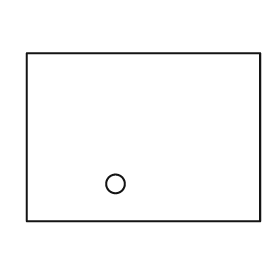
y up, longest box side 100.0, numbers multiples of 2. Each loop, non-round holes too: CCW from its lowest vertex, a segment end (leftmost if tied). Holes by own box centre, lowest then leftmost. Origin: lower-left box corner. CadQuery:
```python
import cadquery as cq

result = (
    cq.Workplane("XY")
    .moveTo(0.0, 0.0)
    .lineTo(100.0, 0.0)
    .lineTo(100.0, 72.0)
    .lineTo(0.0, 72.0)
    .close()
    .moveTo(38.0, 16.0)
    .circle(4.0)
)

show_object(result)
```